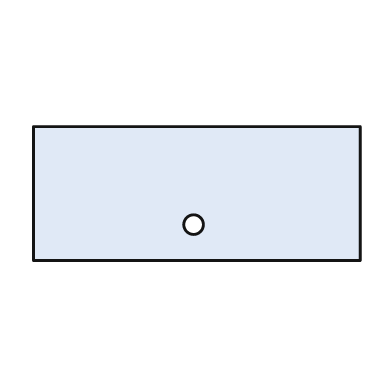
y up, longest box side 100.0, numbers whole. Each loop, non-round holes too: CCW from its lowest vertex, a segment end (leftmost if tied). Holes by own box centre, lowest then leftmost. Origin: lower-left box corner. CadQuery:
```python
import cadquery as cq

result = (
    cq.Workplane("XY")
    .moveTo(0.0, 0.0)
    .lineTo(100.0, 0.0)
    .lineTo(100.0, 41.0)
    .lineTo(0.0, 41.0)
    .close()
    .moveTo(49.0, 11.0)
    .circle(3.0)
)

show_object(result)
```